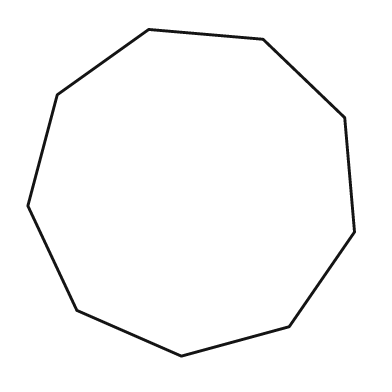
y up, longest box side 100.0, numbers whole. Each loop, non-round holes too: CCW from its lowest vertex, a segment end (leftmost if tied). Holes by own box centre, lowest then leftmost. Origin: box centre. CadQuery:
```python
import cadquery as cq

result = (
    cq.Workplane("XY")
    .moveTo(-3.0, -50.0)
    .lineTo(30.0, -41.0)
    .lineTo(50.0, -12.0)
    .lineTo(47.0, 23.0)
    .lineTo(22.0, 47.0)
    .lineTo(-13.0, 50.0)
    .lineTo(-41.0, 30.0)
    .lineTo(-50.0, -4.0)
    .lineTo(-35.0, -36.0)
    .close()
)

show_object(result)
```